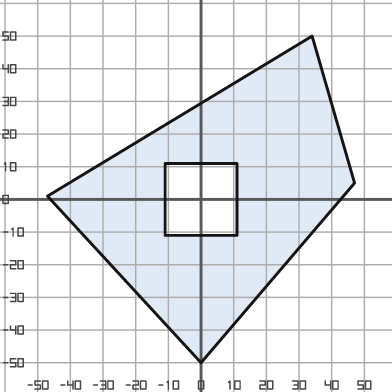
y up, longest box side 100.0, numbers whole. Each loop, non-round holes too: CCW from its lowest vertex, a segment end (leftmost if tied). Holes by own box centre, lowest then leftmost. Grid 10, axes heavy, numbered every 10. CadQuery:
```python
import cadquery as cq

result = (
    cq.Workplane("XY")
    .moveTo(0.0, -50.0)
    .lineTo(47.0, 5.0)
    .lineTo(34.0, 50.0)
    .lineTo(-47.0, 1.0)
    .close()
    .moveTo(-11.0, -11.0)
    .lineTo(11.0, -11.0)
    .lineTo(11.0, 11.0)
    .lineTo(-11.0, 11.0)
    .close()
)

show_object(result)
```